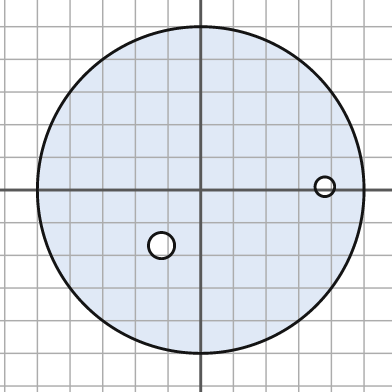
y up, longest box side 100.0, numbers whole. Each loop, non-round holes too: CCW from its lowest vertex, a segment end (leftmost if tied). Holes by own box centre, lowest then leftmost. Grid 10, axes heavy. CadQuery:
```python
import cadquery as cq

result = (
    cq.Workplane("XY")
    .moveTo(0.0, 0.0)
    .circle(50.0)
    .moveTo(-12.0, -17.0)
    .circle(4.0)
    .moveTo(38.0, 1.0)
    .circle(3.0)
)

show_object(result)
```